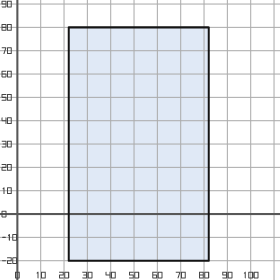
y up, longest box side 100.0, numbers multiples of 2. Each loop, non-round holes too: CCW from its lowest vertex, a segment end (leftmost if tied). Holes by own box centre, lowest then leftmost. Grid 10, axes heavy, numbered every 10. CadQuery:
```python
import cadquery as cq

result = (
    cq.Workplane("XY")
    .moveTo(22.0, -20.0)
    .lineTo(82.0, -20.0)
    .lineTo(82.0, 80.0)
    .lineTo(22.0, 80.0)
    .close()
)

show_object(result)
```